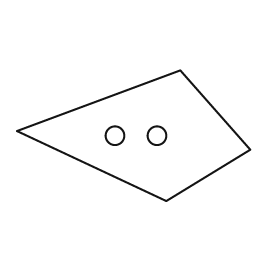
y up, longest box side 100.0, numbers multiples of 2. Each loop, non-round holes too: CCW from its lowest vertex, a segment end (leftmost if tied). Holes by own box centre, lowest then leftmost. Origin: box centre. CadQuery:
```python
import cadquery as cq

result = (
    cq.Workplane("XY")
    .moveTo(14.0, -28.0)
    .lineTo(50.0, -6.0)
    .lineTo(20.0, 28.0)
    .lineTo(-50.0, 2.0)
    .close()
    .moveTo(-8.0, 0.0)
    .circle(4.0)
    .moveTo(10.0, 0.0)
    .circle(4.0)
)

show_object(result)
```